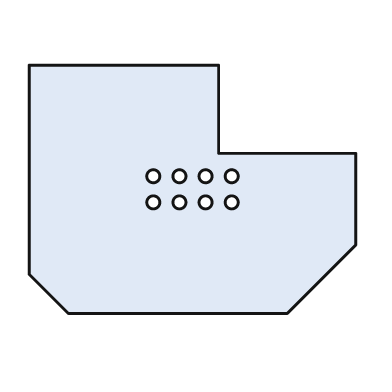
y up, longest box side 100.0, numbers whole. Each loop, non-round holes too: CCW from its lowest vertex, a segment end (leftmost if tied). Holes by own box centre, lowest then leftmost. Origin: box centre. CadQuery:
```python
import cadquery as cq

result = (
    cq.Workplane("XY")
    .moveTo(-38.0, -38.0)
    .lineTo(29.0, -38.0)
    .lineTo(50.0, -17.0)
    .lineTo(50.0, 11.0)
    .lineTo(8.0, 11.0)
    .lineTo(8.0, 38.0)
    .lineTo(-50.0, 38.0)
    .lineTo(-50.0, -26.0)
    .close()
    .moveTo(-12.0, -4.0)
    .circle(2.0)
    .moveTo(-4.0, -4.0)
    .circle(2.0)
    .moveTo(4.0, -4.0)
    .circle(2.0)
    .moveTo(12.0, -4.0)
    .circle(2.0)
    .moveTo(-12.0, 4.0)
    .circle(2.0)
    .moveTo(-4.0, 4.0)
    .circle(2.0)
    .moveTo(4.0, 4.0)
    .circle(2.0)
    .moveTo(12.0, 4.0)
    .circle(2.0)
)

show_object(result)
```